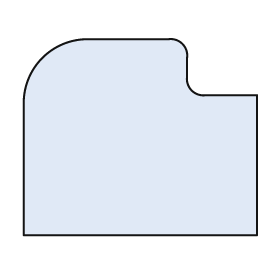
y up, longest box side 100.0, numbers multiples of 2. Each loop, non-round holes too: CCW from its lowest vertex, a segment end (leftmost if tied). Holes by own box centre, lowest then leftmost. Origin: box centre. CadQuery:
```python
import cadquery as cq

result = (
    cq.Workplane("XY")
    .moveTo(-50.0, -42.0)
    .lineTo(50.0, -42.0)
    .lineTo(50.0, 18.0)
    .lineTo(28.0, 18.0)
    .threePointArc((22.0, 20.0), (20.0, 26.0))
    .lineTo(20.0, 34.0)
    .threePointArc((18.0, 40.0), (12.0, 42.0))
    .lineTo(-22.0, 42.0)
    .threePointArc((-42.0, 34.0), (-50.0, 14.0))
    .close()
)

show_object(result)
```